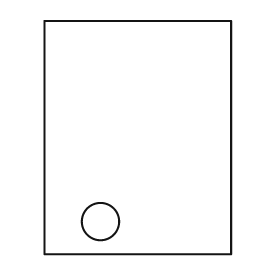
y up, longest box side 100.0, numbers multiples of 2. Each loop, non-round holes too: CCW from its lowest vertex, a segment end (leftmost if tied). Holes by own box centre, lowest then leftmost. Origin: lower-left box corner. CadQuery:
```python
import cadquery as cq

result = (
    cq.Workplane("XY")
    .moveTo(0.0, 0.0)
    .lineTo(80.0, 0.0)
    .lineTo(80.0, 100.0)
    .lineTo(0.0, 100.0)
    .close()
    .moveTo(24.0, 14.0)
    .circle(8.0)
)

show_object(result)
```